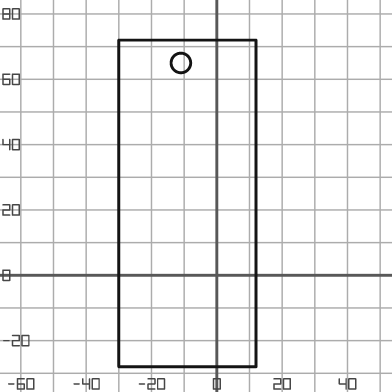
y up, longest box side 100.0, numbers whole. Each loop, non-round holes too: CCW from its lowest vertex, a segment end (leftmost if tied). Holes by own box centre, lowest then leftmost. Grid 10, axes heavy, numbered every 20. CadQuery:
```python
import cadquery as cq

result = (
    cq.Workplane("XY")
    .moveTo(-30.0, -28.0)
    .lineTo(12.0, -28.0)
    .lineTo(12.0, 72.0)
    .lineTo(-30.0, 72.0)
    .close()
    .moveTo(-11.0, 65.0)
    .circle(3.0)
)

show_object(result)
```